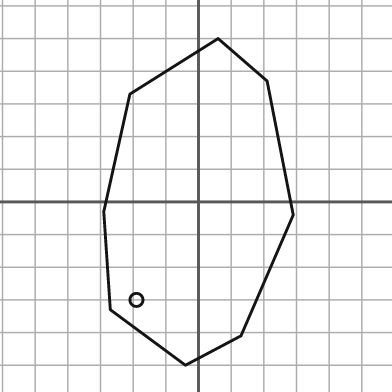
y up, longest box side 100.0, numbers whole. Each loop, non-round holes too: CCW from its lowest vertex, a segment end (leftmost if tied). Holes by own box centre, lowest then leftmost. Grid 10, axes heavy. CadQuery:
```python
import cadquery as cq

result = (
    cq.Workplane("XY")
    .moveTo(-4.0, -50.0)
    .lineTo(13.0, -41.0)
    .lineTo(29.0, -4.0)
    .lineTo(21.0, 37.0)
    .lineTo(6.0, 50.0)
    .lineTo(-21.0, 33.0)
    .lineTo(-29.0, -3.0)
    .lineTo(-27.0, -33.0)
    .close()
    .moveTo(-19.0, -30.0)
    .circle(2.0)
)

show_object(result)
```